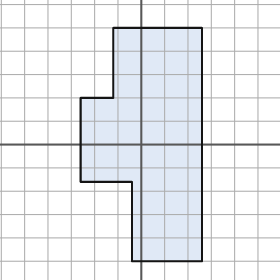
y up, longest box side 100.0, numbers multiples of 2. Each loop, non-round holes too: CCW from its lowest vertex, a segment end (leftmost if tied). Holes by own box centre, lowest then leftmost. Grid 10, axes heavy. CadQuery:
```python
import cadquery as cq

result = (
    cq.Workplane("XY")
    .moveTo(-4.0, -50.0)
    .lineTo(26.0, -50.0)
    .lineTo(26.0, 50.0)
    .lineTo(-12.0, 50.0)
    .lineTo(-12.0, 20.0)
    .lineTo(-26.0, 20.0)
    .lineTo(-26.0, -16.0)
    .lineTo(-4.0, -16.0)
    .close()
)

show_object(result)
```